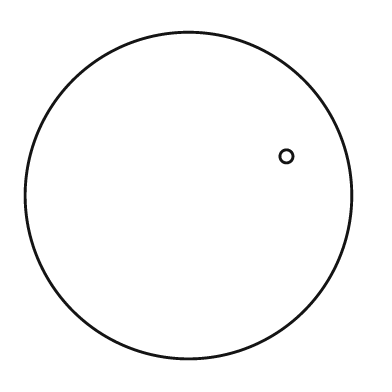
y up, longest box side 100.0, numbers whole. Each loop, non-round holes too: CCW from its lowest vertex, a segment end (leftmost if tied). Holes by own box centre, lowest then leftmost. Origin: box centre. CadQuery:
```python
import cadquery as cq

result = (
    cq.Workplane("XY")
    .moveTo(0.0, 0.0)
    .circle(50.0)
    .moveTo(30.0, 12.0)
    .circle(2.0)
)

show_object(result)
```